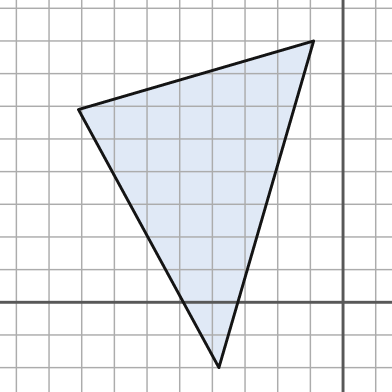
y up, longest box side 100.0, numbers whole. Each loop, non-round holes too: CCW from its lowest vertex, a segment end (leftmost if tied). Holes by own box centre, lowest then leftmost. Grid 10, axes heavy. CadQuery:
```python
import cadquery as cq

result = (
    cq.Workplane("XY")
    .moveTo(-38.0, -20.0)
    .lineTo(-9.0, 80.0)
    .lineTo(-81.0, 59.0)
    .close()
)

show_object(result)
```